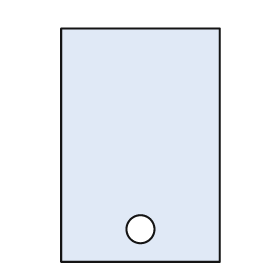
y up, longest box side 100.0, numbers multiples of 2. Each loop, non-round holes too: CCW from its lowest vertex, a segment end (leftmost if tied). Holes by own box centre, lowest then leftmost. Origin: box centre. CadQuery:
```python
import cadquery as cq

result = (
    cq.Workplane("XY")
    .moveTo(-34.0, -50.0)
    .lineTo(34.0, -50.0)
    .lineTo(34.0, 50.0)
    .lineTo(-34.0, 50.0)
    .close()
    .moveTo(0.0, -36.0)
    .circle(6.0)
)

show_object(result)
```